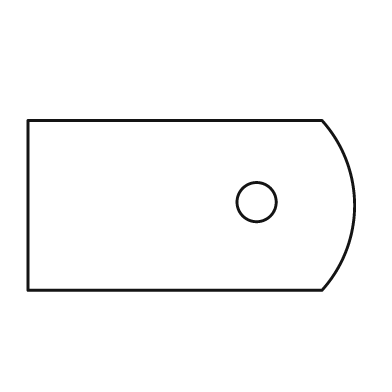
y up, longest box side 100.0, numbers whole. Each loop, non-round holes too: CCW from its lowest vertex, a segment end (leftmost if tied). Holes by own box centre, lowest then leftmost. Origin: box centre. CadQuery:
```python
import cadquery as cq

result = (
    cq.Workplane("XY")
    .moveTo(-50.0, -26.0)
    .lineTo(40.0, -26.0)
    .threePointArc((50.0, 0.0), (40.0, 26.0))
    .lineTo(-50.0, 26.0)
    .close()
    .moveTo(20.0, 1.0)
    .circle(6.0)
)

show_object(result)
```